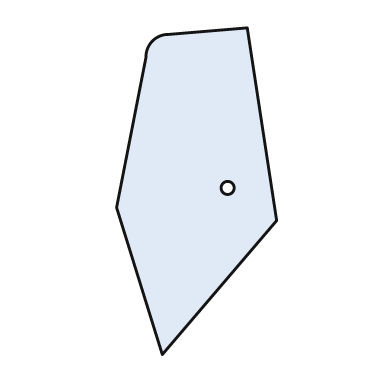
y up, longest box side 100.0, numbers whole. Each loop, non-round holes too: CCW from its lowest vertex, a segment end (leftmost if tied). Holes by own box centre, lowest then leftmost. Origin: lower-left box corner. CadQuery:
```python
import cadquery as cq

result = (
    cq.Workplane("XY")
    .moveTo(14.0, 0.0)
    .lineTo(49.0, 41.0)
    .lineTo(40.0, 100.0)
    .lineTo(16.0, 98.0)
    .threePointArc((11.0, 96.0), (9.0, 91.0))
    .lineTo(0.0, 45.0)
    .close()
    .moveTo(34.0, 51.0)
    .circle(2.0)
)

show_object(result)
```